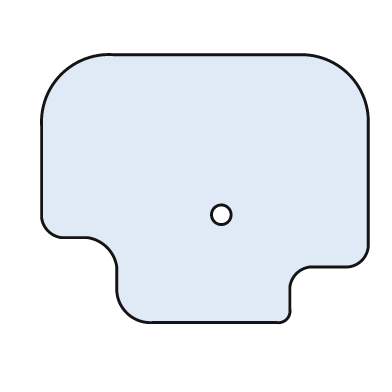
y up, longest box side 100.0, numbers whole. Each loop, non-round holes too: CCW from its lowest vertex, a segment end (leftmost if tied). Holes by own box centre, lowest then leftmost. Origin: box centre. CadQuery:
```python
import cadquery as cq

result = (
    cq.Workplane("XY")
    .moveTo(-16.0, -41.0)
    .lineTo(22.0, -41.0)
    .threePointArc((25.0, -40.0), (26.0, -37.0))
    .lineTo(26.0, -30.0)
    .threePointArc((28.0, -26.0), (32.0, -24.0))
    .lineTo(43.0, -24.0)
    .threePointArc((48.0, -22.0), (50.0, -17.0))
    .lineTo(50.0, 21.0)
    .threePointArc((44.0, 35.0), (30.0, 41.0))
    .lineTo(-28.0, 41.0)
    .threePointArc((-44.0, 35.0), (-50.0, 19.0))
    .lineTo(-50.0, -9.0)
    .threePointArc((-48.0, -13.0), (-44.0, -15.0))
    .lineTo(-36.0, -15.0)
    .threePointArc((-30.0, -18.0), (-27.0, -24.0))
    .lineTo(-27.0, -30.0)
    .threePointArc((-24.0, -38.0), (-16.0, -41.0))
    .close()
    .moveTo(5.0, -8.0)
    .circle(3.0)
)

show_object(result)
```